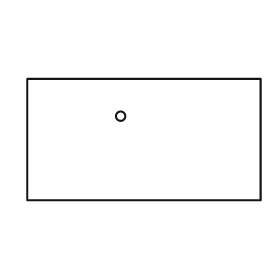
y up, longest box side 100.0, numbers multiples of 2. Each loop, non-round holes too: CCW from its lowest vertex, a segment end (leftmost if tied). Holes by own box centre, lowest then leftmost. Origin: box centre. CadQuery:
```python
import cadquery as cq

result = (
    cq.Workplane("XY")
    .moveTo(-50.0, -26.0)
    .lineTo(50.0, -26.0)
    .lineTo(50.0, 26.0)
    .lineTo(-50.0, 26.0)
    .close()
    .moveTo(-10.0, 10.0)
    .circle(2.0)
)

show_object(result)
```